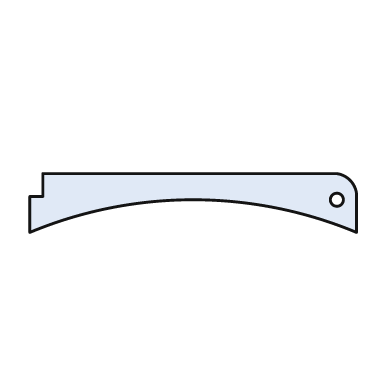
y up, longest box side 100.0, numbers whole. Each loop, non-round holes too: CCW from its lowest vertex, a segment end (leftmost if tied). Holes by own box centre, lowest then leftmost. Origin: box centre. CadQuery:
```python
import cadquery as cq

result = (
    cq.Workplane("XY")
    .moveTo(-50.0, -9.0)
    .threePointArc((0.0, 1.0), (50.0, -9.0))
    .lineTo(50.0, 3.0)
    .threePointArc((48.0, 7.0), (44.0, 9.0))
    .lineTo(-46.0, 9.0)
    .lineTo(-46.0, 2.0)
    .lineTo(-50.0, 2.0)
    .close()
    .moveTo(44.0, 1.0)
    .circle(2.0)
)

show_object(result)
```